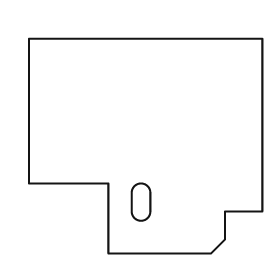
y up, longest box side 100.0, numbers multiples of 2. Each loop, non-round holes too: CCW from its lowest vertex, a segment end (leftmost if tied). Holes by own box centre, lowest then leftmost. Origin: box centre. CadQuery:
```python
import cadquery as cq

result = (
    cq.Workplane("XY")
    .moveTo(-16.0, -46.0)
    .lineTo(28.0, -46.0)
    .lineTo(34.0, -40.0)
    .lineTo(34.0, -28.0)
    .lineTo(50.0, -28.0)
    .lineTo(50.0, 46.0)
    .lineTo(-50.0, 46.0)
    .lineTo(-50.0, -16.0)
    .lineTo(-16.0, -16.0)
    .close()
    .moveTo(-6.0, -28.0)
    .threePointArc((-2.0, -32.0), (2.0, -28.0))
    .lineTo(2.0, -20.0)
    .threePointArc((-2.0, -16.0), (-6.0, -20.0))
    .close()
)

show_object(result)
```